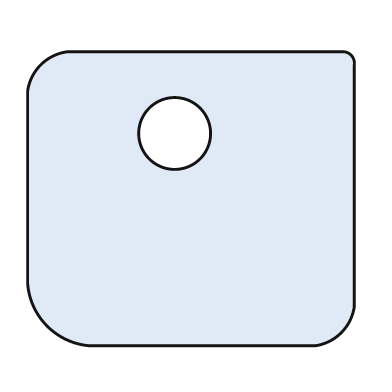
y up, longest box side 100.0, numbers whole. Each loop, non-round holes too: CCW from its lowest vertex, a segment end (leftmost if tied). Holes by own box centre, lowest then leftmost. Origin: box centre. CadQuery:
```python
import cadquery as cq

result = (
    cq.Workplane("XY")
    .moveTo(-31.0, -45.0)
    .lineTo(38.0, -45.0)
    .threePointArc((46.0, -41.0), (50.0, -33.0))
    .lineTo(50.0, 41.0)
    .threePointArc((49.0, 44.0), (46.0, 45.0))
    .lineTo(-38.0, 45.0)
    .threePointArc((-46.0, 41.0), (-50.0, 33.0))
    .lineTo(-50.0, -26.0)
    .threePointArc((-44.0, -39.0), (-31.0, -45.0))
    .close()
    .moveTo(-5.0, 20.0)
    .circle(11.0)
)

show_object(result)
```